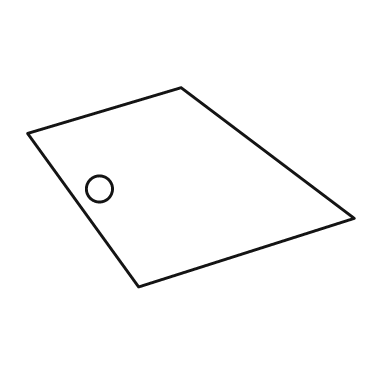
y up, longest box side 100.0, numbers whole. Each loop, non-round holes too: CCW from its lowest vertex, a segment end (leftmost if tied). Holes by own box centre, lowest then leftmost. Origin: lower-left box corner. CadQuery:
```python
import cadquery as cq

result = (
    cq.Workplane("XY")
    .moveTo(34.0, 0.0)
    .lineTo(100.0, 21.0)
    .lineTo(47.0, 61.0)
    .lineTo(0.0, 47.0)
    .close()
    .moveTo(22.0, 30.0)
    .circle(4.0)
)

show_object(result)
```